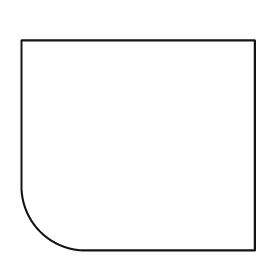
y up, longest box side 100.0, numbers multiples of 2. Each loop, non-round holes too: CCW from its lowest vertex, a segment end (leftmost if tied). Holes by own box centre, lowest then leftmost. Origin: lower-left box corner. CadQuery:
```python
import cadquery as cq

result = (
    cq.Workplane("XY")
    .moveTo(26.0, 0.0)
    .lineTo(100.0, 0.0)
    .lineTo(100.0, 90.0)
    .lineTo(0.0, 90.0)
    .lineTo(0.0, 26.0)
    .threePointArc((8.0, 8.0), (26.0, 0.0))
    .close()
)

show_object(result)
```